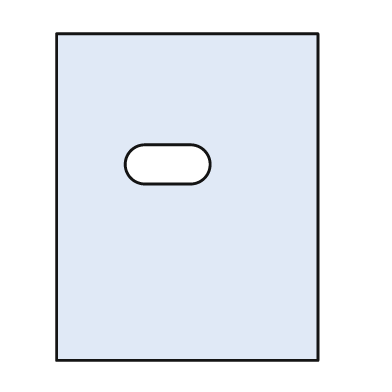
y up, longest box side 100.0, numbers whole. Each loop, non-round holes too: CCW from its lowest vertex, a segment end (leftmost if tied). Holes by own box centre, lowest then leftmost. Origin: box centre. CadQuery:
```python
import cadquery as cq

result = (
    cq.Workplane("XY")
    .moveTo(-40.0, -50.0)
    .lineTo(40.0, -50.0)
    .lineTo(40.0, 50.0)
    .lineTo(-40.0, 50.0)
    .close()
    .moveTo(-13.0, 4.0)
    .lineTo(1.0, 4.0)
    .threePointArc((7.0, 10.0), (1.0, 16.0))
    .lineTo(-13.0, 16.0)
    .threePointArc((-19.0, 10.0), (-13.0, 4.0))
    .close()
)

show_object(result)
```